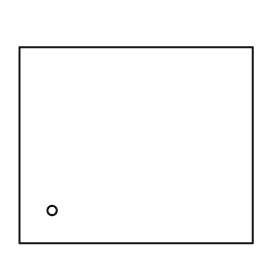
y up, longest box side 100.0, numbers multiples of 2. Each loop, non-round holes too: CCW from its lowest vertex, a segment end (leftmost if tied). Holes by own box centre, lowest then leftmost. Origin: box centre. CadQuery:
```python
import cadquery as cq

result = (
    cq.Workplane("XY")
    .moveTo(-50.0, -42.0)
    .lineTo(50.0, -42.0)
    .lineTo(50.0, 42.0)
    .lineTo(-50.0, 42.0)
    .close()
    .moveTo(-36.0, -28.0)
    .circle(2.0)
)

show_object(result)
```